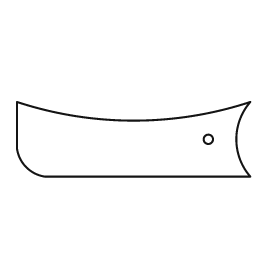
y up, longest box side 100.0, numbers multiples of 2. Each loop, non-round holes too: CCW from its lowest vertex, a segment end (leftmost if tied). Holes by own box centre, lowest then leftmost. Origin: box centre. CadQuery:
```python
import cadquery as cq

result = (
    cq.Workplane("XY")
    .moveTo(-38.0, -16.0)
    .lineTo(50.0, -16.0)
    .threePointArc((44.0, 0.0), (50.0, 16.0))
    .threePointArc((0.0, 8.0), (-50.0, 16.0))
    .lineTo(-50.0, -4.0)
    .threePointArc((-46.0, -12.0), (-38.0, -16.0))
    .close()
    .moveTo(32.0, 0.0)
    .circle(2.0)
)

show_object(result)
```